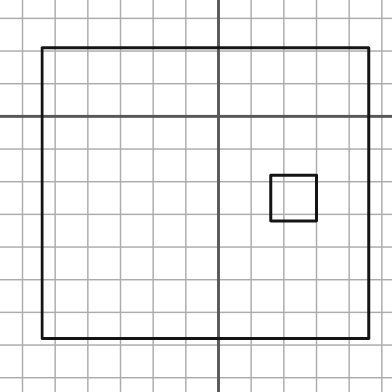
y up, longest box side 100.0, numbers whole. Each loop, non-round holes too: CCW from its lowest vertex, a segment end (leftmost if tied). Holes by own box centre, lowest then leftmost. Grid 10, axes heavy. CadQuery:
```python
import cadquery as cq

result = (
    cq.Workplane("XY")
    .moveTo(-54.0, -68.0)
    .lineTo(46.0, -68.0)
    .lineTo(46.0, 21.0)
    .lineTo(-54.0, 21.0)
    .close()
    .moveTo(16.0, -32.0)
    .lineTo(30.0, -32.0)
    .lineTo(30.0, -18.0)
    .lineTo(16.0, -18.0)
    .close()
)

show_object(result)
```